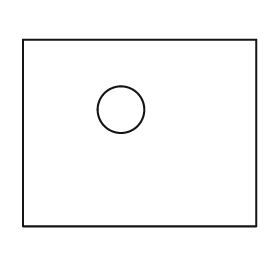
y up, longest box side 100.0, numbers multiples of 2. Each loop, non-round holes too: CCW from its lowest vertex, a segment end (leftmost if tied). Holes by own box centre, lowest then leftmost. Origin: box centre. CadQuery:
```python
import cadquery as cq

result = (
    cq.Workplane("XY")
    .moveTo(-50.0, -40.0)
    .lineTo(50.0, -40.0)
    .lineTo(50.0, 40.0)
    .lineTo(-50.0, 40.0)
    .close()
    .moveTo(-8.0, 10.0)
    .circle(10.0)
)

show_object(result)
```